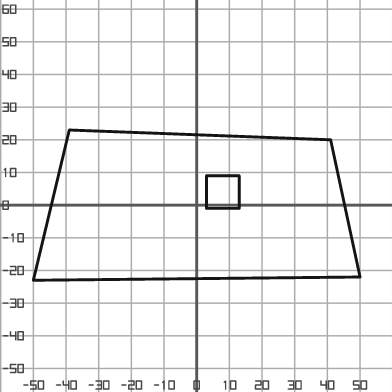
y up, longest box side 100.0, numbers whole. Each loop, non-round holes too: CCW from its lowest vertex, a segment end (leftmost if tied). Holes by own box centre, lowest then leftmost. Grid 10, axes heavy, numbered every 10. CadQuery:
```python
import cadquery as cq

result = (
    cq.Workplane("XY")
    .moveTo(-50.0, -23.0)
    .lineTo(50.0, -22.0)
    .lineTo(41.0, 20.0)
    .lineTo(-39.0, 23.0)
    .close()
    .moveTo(3.0, -1.0)
    .lineTo(13.0, -1.0)
    .lineTo(13.0, 9.0)
    .lineTo(3.0, 9.0)
    .close()
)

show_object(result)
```